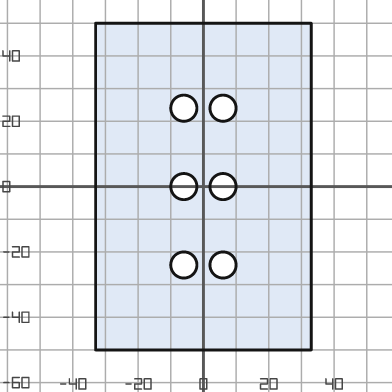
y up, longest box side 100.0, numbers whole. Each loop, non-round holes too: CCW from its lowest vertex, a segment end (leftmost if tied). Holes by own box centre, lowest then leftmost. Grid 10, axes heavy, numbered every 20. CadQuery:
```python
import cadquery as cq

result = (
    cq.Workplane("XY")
    .moveTo(-33.0, -50.0)
    .lineTo(33.0, -50.0)
    .lineTo(33.0, 50.0)
    .lineTo(-33.0, 50.0)
    .close()
    .moveTo(-6.0, -24.0)
    .circle(4.0)
    .moveTo(6.0, -24.0)
    .circle(4.0)
    .moveTo(-6.0, 0.0)
    .circle(4.0)
    .moveTo(6.0, 0.0)
    .circle(4.0)
    .moveTo(-6.0, 24.0)
    .circle(4.0)
    .moveTo(6.0, 24.0)
    .circle(4.0)
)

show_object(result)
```